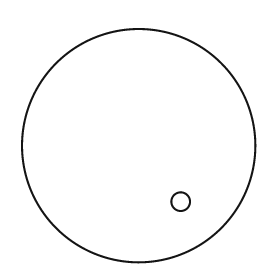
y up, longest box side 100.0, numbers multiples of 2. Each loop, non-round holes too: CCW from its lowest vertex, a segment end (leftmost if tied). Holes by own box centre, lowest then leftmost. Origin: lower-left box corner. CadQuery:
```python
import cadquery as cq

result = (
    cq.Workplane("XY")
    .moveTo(50.0, 50.0)
    .circle(50.0)
    .moveTo(68.0, 26.0)
    .circle(4.0)
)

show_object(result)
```